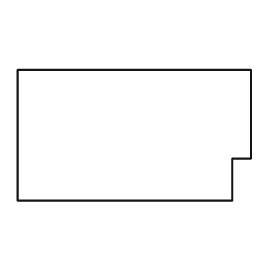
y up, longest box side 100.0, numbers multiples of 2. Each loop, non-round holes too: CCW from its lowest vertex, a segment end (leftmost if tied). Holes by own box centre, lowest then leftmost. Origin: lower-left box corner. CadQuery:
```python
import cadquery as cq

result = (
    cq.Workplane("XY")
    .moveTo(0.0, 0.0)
    .lineTo(92.0, 0.0)
    .lineTo(92.0, 18.0)
    .lineTo(100.0, 18.0)
    .lineTo(100.0, 56.0)
    .lineTo(0.0, 56.0)
    .close()
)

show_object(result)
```